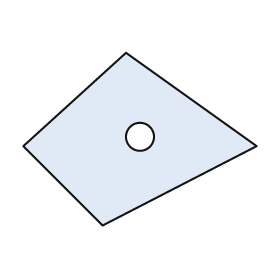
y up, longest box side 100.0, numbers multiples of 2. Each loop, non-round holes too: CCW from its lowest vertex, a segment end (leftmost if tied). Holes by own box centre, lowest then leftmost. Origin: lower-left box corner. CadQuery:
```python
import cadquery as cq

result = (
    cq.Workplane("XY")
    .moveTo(34.0, 0.0)
    .lineTo(100.0, 34.0)
    .lineTo(44.0, 74.0)
    .lineTo(0.0, 34.0)
    .close()
    .moveTo(50.0, 38.0)
    .circle(6.0)
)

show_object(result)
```